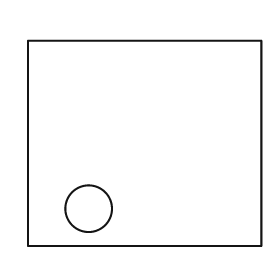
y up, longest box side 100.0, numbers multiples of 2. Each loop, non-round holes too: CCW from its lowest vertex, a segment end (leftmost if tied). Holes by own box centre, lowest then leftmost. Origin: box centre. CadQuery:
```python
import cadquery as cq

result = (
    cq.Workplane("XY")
    .moveTo(-50.0, -44.0)
    .lineTo(50.0, -44.0)
    .lineTo(50.0, 44.0)
    .lineTo(-50.0, 44.0)
    .close()
    .moveTo(-24.0, -28.0)
    .circle(10.0)
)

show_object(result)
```